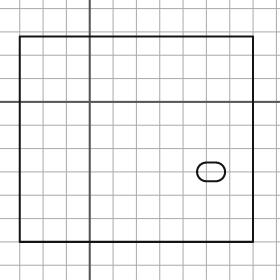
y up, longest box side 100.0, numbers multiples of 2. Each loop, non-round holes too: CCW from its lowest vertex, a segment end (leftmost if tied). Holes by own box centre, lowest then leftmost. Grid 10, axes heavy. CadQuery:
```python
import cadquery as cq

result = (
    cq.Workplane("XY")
    .moveTo(-30.0, -60.0)
    .lineTo(70.0, -60.0)
    .lineTo(70.0, 28.0)
    .lineTo(-30.0, 28.0)
    .close()
    .moveTo(50.0, -34.0)
    .lineTo(54.0, -34.0)
    .threePointArc((58.0, -30.0), (54.0, -26.0))
    .lineTo(50.0, -26.0)
    .threePointArc((46.0, -30.0), (50.0, -34.0))
    .close()
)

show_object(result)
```